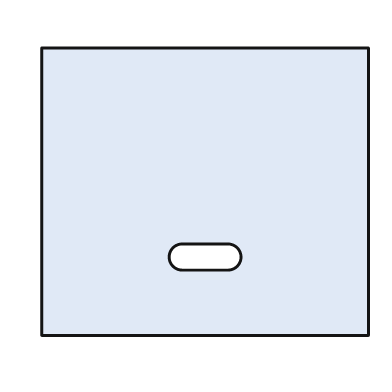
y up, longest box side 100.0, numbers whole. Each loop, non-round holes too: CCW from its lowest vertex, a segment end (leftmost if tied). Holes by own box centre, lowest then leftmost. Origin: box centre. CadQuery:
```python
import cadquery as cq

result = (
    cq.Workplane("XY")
    .moveTo(-50.0, -44.0)
    .lineTo(50.0, -44.0)
    .lineTo(50.0, 44.0)
    .lineTo(-50.0, 44.0)
    .close()
    .moveTo(-7.0, -24.0)
    .lineTo(7.0, -24.0)
    .threePointArc((11.0, -20.0), (7.0, -16.0))
    .lineTo(-7.0, -16.0)
    .threePointArc((-11.0, -20.0), (-7.0, -24.0))
    .close()
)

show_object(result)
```